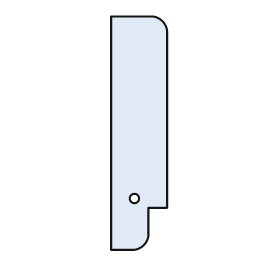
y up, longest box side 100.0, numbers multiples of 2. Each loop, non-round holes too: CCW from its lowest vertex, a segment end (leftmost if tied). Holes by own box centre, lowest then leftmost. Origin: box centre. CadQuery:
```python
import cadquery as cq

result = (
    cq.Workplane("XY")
    .moveTo(-12.0, -50.0)
    .lineTo(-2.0, -50.0)
    .threePointArc((2.0, -48.0), (4.0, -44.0))
    .lineTo(4.0, -32.0)
    .lineTo(12.0, -32.0)
    .lineTo(12.0, 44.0)
    .threePointArc((10.0, 48.0), (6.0, 50.0))
    .lineTo(-12.0, 50.0)
    .close()
    .moveTo(-2.0, -28.0)
    .circle(2.0)
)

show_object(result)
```